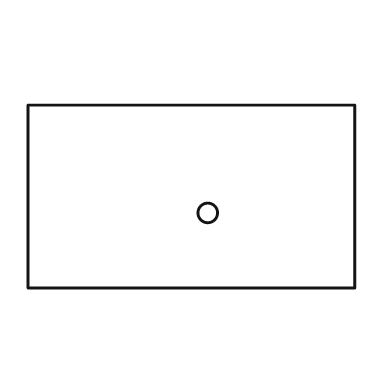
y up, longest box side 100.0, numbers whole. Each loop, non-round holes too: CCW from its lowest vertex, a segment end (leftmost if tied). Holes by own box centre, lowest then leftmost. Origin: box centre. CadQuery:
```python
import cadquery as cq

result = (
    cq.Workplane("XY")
    .moveTo(-50.0, -28.0)
    .lineTo(50.0, -28.0)
    .lineTo(50.0, 28.0)
    .lineTo(-50.0, 28.0)
    .close()
    .moveTo(5.0, -5.0)
    .circle(3.0)
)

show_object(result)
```